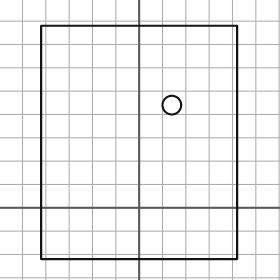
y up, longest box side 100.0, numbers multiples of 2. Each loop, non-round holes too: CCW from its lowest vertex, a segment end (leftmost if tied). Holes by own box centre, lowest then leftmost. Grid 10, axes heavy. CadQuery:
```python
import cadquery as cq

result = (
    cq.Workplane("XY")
    .moveTo(-42.0, -22.0)
    .lineTo(42.0, -22.0)
    .lineTo(42.0, 78.0)
    .lineTo(-42.0, 78.0)
    .close()
    .moveTo(14.0, 44.0)
    .circle(4.0)
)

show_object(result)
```